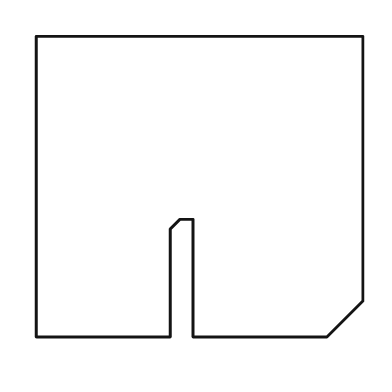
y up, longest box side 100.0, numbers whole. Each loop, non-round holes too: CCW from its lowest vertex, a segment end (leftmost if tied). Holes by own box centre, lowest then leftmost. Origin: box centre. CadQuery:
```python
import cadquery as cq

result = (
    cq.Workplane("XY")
    .moveTo(-50.0, -46.0)
    .lineTo(-9.0, -46.0)
    .lineTo(-9.0, -13.0)
    .lineTo(-6.0, -10.0)
    .lineTo(-2.0, -10.0)
    .lineTo(-2.0, -46.0)
    .lineTo(39.0, -46.0)
    .lineTo(50.0, -35.0)
    .lineTo(50.0, 46.0)
    .lineTo(-50.0, 46.0)
    .close()
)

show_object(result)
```